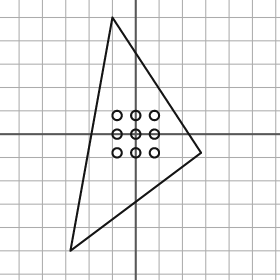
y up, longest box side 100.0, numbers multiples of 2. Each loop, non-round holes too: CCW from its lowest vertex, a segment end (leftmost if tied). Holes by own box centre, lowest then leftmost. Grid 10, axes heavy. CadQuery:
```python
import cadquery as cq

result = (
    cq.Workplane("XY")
    .moveTo(-28.0, -50.0)
    .lineTo(28.0, -8.0)
    .lineTo(-10.0, 50.0)
    .close()
    .moveTo(-8.0, -8.0)
    .circle(2.0)
    .moveTo(0.0, -8.0)
    .circle(2.0)
    .moveTo(8.0, -8.0)
    .circle(2.0)
    .moveTo(-8.0, 0.0)
    .circle(2.0)
    .moveTo(0.0, 0.0)
    .circle(2.0)
    .moveTo(8.0, 0.0)
    .circle(2.0)
    .moveTo(-8.0, 8.0)
    .circle(2.0)
    .moveTo(0.0, 8.0)
    .circle(2.0)
    .moveTo(8.0, 8.0)
    .circle(2.0)
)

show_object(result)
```